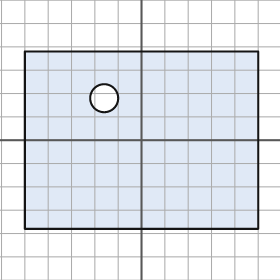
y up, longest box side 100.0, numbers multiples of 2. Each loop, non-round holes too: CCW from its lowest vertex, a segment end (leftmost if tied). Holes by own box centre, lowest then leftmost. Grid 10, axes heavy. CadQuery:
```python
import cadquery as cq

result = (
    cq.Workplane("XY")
    .moveTo(-50.0, -38.0)
    .lineTo(50.0, -38.0)
    .lineTo(50.0, 38.0)
    .lineTo(-50.0, 38.0)
    .close()
    .moveTo(-16.0, 18.0)
    .circle(6.0)
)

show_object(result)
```